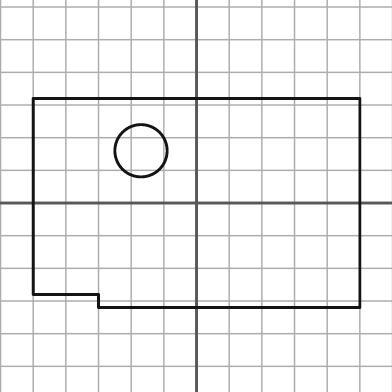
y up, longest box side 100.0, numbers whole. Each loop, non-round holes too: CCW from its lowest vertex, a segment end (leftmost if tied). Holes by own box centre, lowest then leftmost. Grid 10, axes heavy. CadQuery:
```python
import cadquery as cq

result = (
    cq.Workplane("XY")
    .moveTo(-30.0, -32.0)
    .lineTo(50.0, -32.0)
    .lineTo(50.0, 32.0)
    .lineTo(-50.0, 32.0)
    .lineTo(-50.0, -28.0)
    .lineTo(-30.0, -28.0)
    .close()
    .moveTo(-17.0, 16.0)
    .circle(8.0)
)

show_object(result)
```